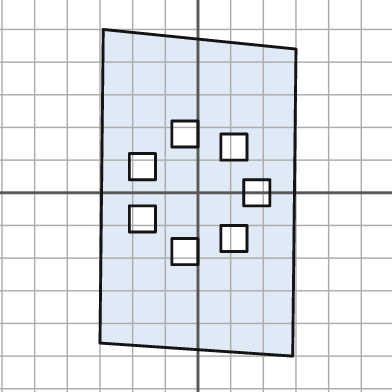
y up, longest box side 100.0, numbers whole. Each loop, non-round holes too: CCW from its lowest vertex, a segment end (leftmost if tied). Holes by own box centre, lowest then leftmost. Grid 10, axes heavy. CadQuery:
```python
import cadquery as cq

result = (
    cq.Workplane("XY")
    .moveTo(29.0, -50.0)
    .lineTo(30.0, 44.0)
    .lineTo(-29.0, 50.0)
    .lineTo(-30.0, -46.0)
    .close()
    .moveTo(-8.0, -22.0)
    .lineTo(0.0, -22.0)
    .lineTo(0.0, -14.0)
    .lineTo(-8.0, -14.0)
    .close()
    .moveTo(7.0, -18.0)
    .lineTo(15.0, -18.0)
    .lineTo(15.0, -10.0)
    .lineTo(7.0, -10.0)
    .close()
    .moveTo(-21.0, -12.0)
    .lineTo(-13.0, -12.0)
    .lineTo(-13.0, -4.0)
    .lineTo(-21.0, -4.0)
    .close()
    .moveTo(14.0, -4.0)
    .lineTo(22.0, -4.0)
    .lineTo(22.0, 4.0)
    .lineTo(14.0, 4.0)
    .close()
    .moveTo(-21.0, 4.0)
    .lineTo(-13.0, 4.0)
    .lineTo(-13.0, 12.0)
    .lineTo(-21.0, 12.0)
    .close()
    .moveTo(7.0, 10.0)
    .lineTo(15.0, 10.0)
    .lineTo(15.0, 18.0)
    .lineTo(7.0, 18.0)
    .close()
    .moveTo(-8.0, 14.0)
    .lineTo(0.0, 14.0)
    .lineTo(0.0, 22.0)
    .lineTo(-8.0, 22.0)
    .close()
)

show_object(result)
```